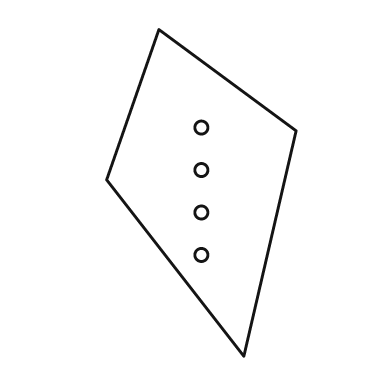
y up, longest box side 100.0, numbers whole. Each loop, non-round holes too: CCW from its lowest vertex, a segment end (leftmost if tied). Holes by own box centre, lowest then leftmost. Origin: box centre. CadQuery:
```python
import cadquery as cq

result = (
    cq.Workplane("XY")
    .moveTo(13.0, -50.0)
    .lineTo(29.0, 19.0)
    .lineTo(-13.0, 50.0)
    .lineTo(-29.0, 4.0)
    .close()
    .moveTo(0.0, -19.0)
    .circle(2.0)
    .moveTo(0.0, -6.0)
    .circle(2.0)
    .moveTo(0.0, 7.0)
    .circle(2.0)
    .moveTo(0.0, 20.0)
    .circle(2.0)
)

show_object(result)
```